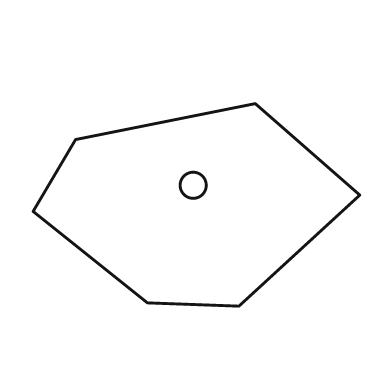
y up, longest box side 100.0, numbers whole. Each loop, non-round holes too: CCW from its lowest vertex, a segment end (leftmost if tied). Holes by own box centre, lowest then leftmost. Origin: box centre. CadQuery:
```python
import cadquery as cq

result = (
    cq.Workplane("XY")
    .moveTo(13.0, -31.0)
    .lineTo(50.0, 3.0)
    .lineTo(18.0, 31.0)
    .lineTo(-37.0, 20.0)
    .lineTo(-50.0, -2.0)
    .lineTo(-15.0, -30.0)
    .close()
    .moveTo(-1.0, 6.0)
    .circle(4.0)
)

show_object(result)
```